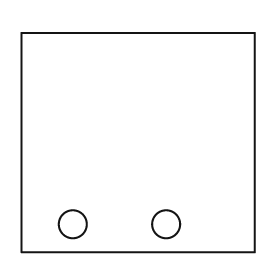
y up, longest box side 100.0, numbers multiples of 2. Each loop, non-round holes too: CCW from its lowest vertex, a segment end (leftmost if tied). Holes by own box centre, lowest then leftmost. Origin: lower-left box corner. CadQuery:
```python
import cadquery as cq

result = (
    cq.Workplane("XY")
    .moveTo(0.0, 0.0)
    .lineTo(100.0, 0.0)
    .lineTo(100.0, 94.0)
    .lineTo(0.0, 94.0)
    .close()
    .moveTo(22.0, 12.0)
    .circle(6.0)
    .moveTo(62.0, 12.0)
    .circle(6.0)
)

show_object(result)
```